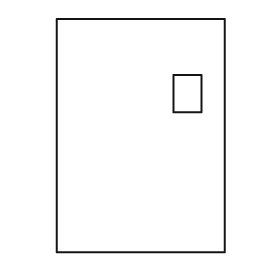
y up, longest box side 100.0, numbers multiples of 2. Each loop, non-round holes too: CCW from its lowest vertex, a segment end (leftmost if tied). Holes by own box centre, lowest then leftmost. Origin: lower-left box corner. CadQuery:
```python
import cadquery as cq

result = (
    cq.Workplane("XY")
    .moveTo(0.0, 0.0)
    .lineTo(72.0, 0.0)
    .lineTo(72.0, 100.0)
    .lineTo(0.0, 100.0)
    .close()
    .moveTo(50.0, 60.0)
    .lineTo(62.0, 60.0)
    .lineTo(62.0, 76.0)
    .lineTo(50.0, 76.0)
    .close()
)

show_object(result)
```